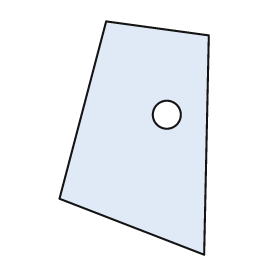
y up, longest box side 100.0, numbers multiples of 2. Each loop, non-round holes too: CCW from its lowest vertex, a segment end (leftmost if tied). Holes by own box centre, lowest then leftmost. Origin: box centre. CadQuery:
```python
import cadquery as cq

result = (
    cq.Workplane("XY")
    .moveTo(30.0, -50.0)
    .lineTo(32.0, 44.0)
    .lineTo(-12.0, 50.0)
    .lineTo(-32.0, -26.0)
    .close()
    .moveTo(14.0, 10.0)
    .circle(6.0)
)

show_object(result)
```